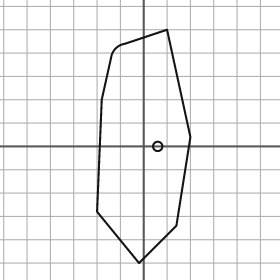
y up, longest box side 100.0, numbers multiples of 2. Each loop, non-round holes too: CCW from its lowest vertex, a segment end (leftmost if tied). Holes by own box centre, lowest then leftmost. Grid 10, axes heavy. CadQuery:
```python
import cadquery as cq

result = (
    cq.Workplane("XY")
    .moveTo(-2.0, -50.0)
    .lineTo(14.0, -34.0)
    .lineTo(20.0, 4.0)
    .lineTo(10.0, 50.0)
    .lineTo(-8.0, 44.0)
    .threePointArc((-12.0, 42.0), (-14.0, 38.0))
    .lineTo(-18.0, 20.0)
    .lineTo(-20.0, -28.0)
    .close()
    .moveTo(6.0, 0.0)
    .circle(2.0)
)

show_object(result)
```